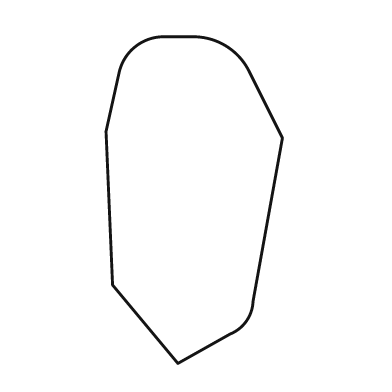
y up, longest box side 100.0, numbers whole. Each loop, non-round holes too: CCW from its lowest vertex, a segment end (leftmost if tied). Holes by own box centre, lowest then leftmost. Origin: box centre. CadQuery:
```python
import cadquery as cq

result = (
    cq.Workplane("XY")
    .moveTo(-5.0, -50.0)
    .lineTo(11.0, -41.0)
    .threePointArc((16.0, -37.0), (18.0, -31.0))
    .lineTo(27.0, 19.0)
    .lineTo(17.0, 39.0)
    .threePointArc((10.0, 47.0), (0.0, 50.0))
    .lineTo(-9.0, 50.0)
    .threePointArc((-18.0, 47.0), (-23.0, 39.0))
    .lineTo(-27.0, 21.0)
    .lineTo(-25.0, -26.0)
    .close()
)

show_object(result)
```